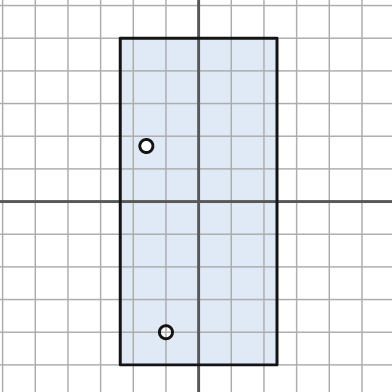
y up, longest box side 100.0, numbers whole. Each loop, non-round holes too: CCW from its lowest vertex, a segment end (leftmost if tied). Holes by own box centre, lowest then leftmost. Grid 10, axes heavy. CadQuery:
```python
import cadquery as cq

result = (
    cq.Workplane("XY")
    .moveTo(-24.0, -50.0)
    .lineTo(24.0, -50.0)
    .lineTo(24.0, 50.0)
    .lineTo(-24.0, 50.0)
    .close()
    .moveTo(-10.0, -40.0)
    .circle(2.0)
    .moveTo(-16.0, 17.0)
    .circle(2.0)
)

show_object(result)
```